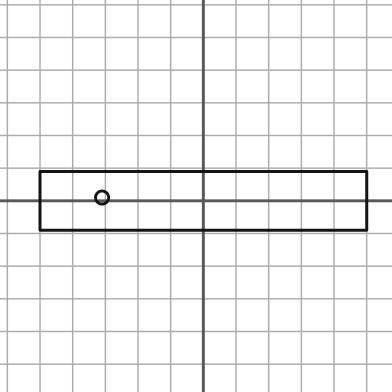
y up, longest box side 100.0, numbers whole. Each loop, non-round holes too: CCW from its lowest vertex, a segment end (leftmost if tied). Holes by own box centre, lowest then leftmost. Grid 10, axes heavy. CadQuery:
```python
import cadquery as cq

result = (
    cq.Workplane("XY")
    .moveTo(-50.0, -9.0)
    .lineTo(50.0, -9.0)
    .lineTo(50.0, 9.0)
    .lineTo(-50.0, 9.0)
    .close()
    .moveTo(-31.0, 1.0)
    .circle(2.0)
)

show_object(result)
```